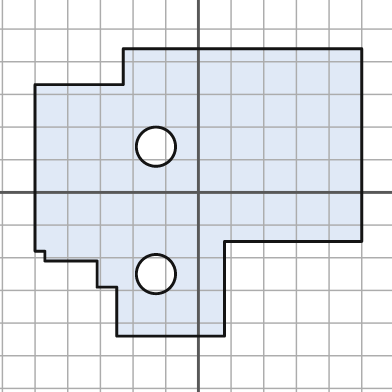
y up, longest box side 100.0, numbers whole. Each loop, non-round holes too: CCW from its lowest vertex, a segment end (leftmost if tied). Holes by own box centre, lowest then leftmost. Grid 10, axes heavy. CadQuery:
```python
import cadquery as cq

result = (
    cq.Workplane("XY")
    .moveTo(-25.0, -44.0)
    .lineTo(8.0, -44.0)
    .lineTo(8.0, -15.0)
    .lineTo(50.0, -15.0)
    .lineTo(50.0, 44.0)
    .lineTo(-23.0, 44.0)
    .lineTo(-23.0, 33.0)
    .lineTo(-50.0, 33.0)
    .lineTo(-50.0, -18.0)
    .lineTo(-47.0, -18.0)
    .lineTo(-47.0, -21.0)
    .lineTo(-31.0, -21.0)
    .lineTo(-31.0, -29.0)
    .lineTo(-25.0, -29.0)
    .close()
    .moveTo(-13.0, -25.0)
    .circle(6.0)
    .moveTo(-13.0, 14.0)
    .circle(6.0)
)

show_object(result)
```